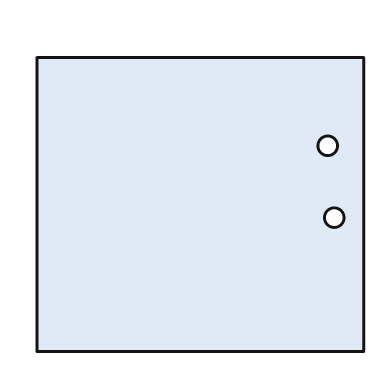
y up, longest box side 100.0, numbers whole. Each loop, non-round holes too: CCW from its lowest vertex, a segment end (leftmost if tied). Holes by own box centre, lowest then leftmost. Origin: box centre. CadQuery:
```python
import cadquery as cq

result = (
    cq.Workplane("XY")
    .moveTo(-50.0, -45.0)
    .lineTo(50.0, -45.0)
    .lineTo(50.0, 45.0)
    .lineTo(-50.0, 45.0)
    .close()
    .moveTo(41.0, -4.0)
    .circle(3.0)
    .moveTo(39.0, 18.0)
    .circle(3.0)
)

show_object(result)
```